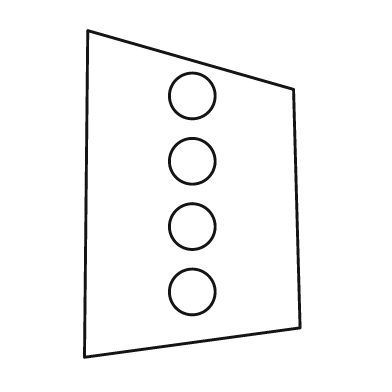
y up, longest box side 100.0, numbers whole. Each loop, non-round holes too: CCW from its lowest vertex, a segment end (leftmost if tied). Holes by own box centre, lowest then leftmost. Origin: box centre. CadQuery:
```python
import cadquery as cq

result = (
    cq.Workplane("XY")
    .moveTo(-33.0, -50.0)
    .lineTo(33.0, -41.0)
    .lineTo(31.0, 32.0)
    .lineTo(-32.0, 50.0)
    .close()
    .moveTo(0.0, -30.0)
    .circle(7.0)
    .moveTo(0.0, -10.0)
    .circle(7.0)
    .moveTo(0.0, 10.0)
    .circle(7.0)
    .moveTo(0.0, 30.0)
    .circle(7.0)
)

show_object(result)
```